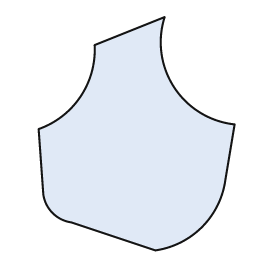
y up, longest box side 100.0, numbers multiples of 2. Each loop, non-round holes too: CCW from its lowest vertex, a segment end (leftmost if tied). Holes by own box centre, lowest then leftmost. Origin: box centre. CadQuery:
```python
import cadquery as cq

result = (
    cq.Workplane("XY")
    .moveTo(8.0, -50.0)
    .threePointArc((28.0, -40.0), (38.0, -20.0))
    .lineTo(42.0, 4.0)
    .threePointArc((16.0, 20.0), (12.0, 50.0))
    .lineTo(-18.0, 38.0)
    .threePointArc((-24.0, 16.0), (-42.0, 2.0))
    .lineTo(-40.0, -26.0)
    .threePointArc((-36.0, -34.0), (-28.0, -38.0))
    .close()
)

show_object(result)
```